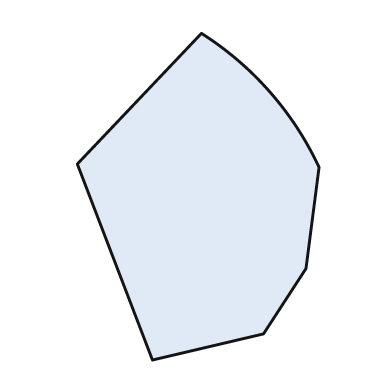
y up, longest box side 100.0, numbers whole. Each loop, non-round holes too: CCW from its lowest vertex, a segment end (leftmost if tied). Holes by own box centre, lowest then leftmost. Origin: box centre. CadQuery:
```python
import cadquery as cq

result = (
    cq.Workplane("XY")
    .moveTo(-14.0, -50.0)
    .lineTo(20.0, -42.0)
    .lineTo(33.0, -22.0)
    .lineTo(37.0, 9.0)
    .threePointArc((22.0, 32.0), (1.0, 50.0))
    .lineTo(-37.0, 10.0)
    .close()
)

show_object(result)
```